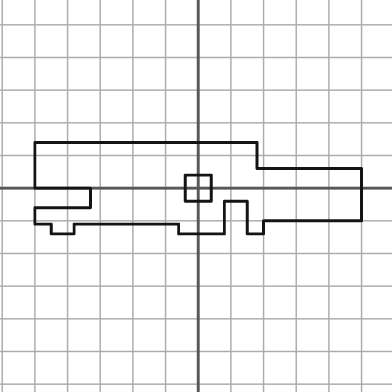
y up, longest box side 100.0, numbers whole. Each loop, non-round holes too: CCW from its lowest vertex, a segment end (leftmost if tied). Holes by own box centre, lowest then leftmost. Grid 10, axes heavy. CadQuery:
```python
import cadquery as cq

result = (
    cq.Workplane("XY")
    .moveTo(-45.0, -14.0)
    .lineTo(-38.0, -14.0)
    .lineTo(-38.0, -11.0)
    .lineTo(-6.0, -11.0)
    .lineTo(-6.0, -14.0)
    .lineTo(8.0, -14.0)
    .lineTo(8.0, -4.0)
    .lineTo(15.0, -4.0)
    .lineTo(15.0, -14.0)
    .lineTo(20.0, -14.0)
    .lineTo(20.0, -10.0)
    .lineTo(50.0, -10.0)
    .lineTo(50.0, 6.0)
    .lineTo(18.0, 6.0)
    .lineTo(18.0, 14.0)
    .lineTo(-50.0, 14.0)
    .lineTo(-50.0, 0.0)
    .lineTo(-33.0, 0.0)
    .lineTo(-33.0, -6.0)
    .lineTo(-50.0, -6.0)
    .lineTo(-50.0, -11.0)
    .lineTo(-45.0, -11.0)
    .close()
    .moveTo(-4.0, -4.0)
    .lineTo(4.0, -4.0)
    .lineTo(4.0, 4.0)
    .lineTo(-4.0, 4.0)
    .close()
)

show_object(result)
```